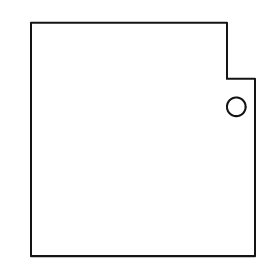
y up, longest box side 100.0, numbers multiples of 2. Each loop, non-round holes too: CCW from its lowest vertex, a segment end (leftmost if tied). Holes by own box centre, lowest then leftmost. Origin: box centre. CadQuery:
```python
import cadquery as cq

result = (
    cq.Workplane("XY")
    .moveTo(-48.0, -50.0)
    .lineTo(48.0, -50.0)
    .lineTo(48.0, 26.0)
    .lineTo(36.0, 26.0)
    .lineTo(36.0, 50.0)
    .lineTo(-48.0, 50.0)
    .close()
    .moveTo(40.0, 14.0)
    .circle(4.0)
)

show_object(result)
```